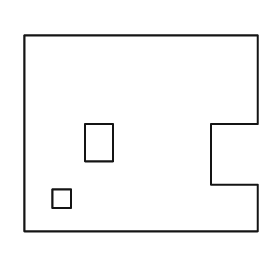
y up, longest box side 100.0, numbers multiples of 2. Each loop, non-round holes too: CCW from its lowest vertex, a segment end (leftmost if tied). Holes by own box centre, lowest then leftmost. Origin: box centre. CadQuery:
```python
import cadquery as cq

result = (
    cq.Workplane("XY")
    .moveTo(-50.0, -42.0)
    .lineTo(50.0, -42.0)
    .lineTo(50.0, -22.0)
    .lineTo(30.0, -22.0)
    .lineTo(30.0, 4.0)
    .lineTo(50.0, 4.0)
    .lineTo(50.0, 42.0)
    .lineTo(-50.0, 42.0)
    .close()
    .moveTo(-38.0, -32.0)
    .lineTo(-30.0, -32.0)
    .lineTo(-30.0, -24.0)
    .lineTo(-38.0, -24.0)
    .close()
    .moveTo(-24.0, -12.0)
    .lineTo(-12.0, -12.0)
    .lineTo(-12.0, 4.0)
    .lineTo(-24.0, 4.0)
    .close()
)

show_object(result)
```